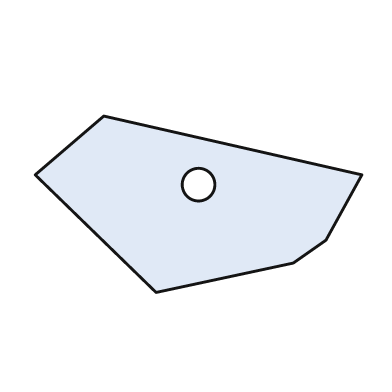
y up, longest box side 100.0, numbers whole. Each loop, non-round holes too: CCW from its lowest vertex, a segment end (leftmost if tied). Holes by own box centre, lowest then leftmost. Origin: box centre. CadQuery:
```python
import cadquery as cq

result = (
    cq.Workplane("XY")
    .moveTo(-13.0, -27.0)
    .lineTo(29.0, -18.0)
    .lineTo(39.0, -11.0)
    .lineTo(50.0, 9.0)
    .lineTo(-29.0, 27.0)
    .lineTo(-50.0, 9.0)
    .close()
    .moveTo(0.0, 6.0)
    .circle(5.0)
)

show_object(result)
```